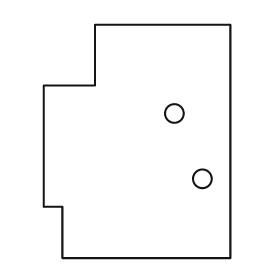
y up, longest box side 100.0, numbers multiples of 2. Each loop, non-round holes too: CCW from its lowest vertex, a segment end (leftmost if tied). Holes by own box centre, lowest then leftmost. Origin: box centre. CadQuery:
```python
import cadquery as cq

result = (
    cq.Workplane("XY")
    .moveTo(-32.0, -50.0)
    .lineTo(40.0, -50.0)
    .lineTo(40.0, 50.0)
    .lineTo(-18.0, 50.0)
    .lineTo(-18.0, 24.0)
    .lineTo(-40.0, 24.0)
    .lineTo(-40.0, -28.0)
    .lineTo(-32.0, -28.0)
    .close()
    .moveTo(28.0, -16.0)
    .circle(4.0)
    .moveTo(16.0, 12.0)
    .circle(4.0)
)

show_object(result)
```